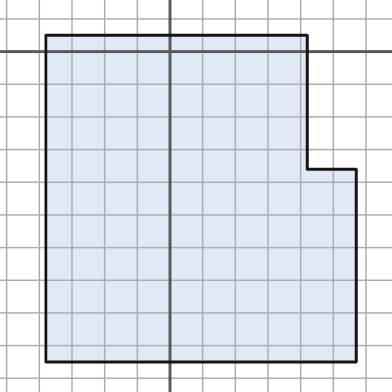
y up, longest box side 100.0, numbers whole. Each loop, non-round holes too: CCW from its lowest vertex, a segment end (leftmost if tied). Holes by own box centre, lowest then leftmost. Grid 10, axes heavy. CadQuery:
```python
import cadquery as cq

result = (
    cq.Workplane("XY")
    .moveTo(-38.0, -95.0)
    .lineTo(57.0, -95.0)
    .lineTo(57.0, -36.0)
    .lineTo(42.0, -36.0)
    .lineTo(42.0, 5.0)
    .lineTo(-38.0, 5.0)
    .close()
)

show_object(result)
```